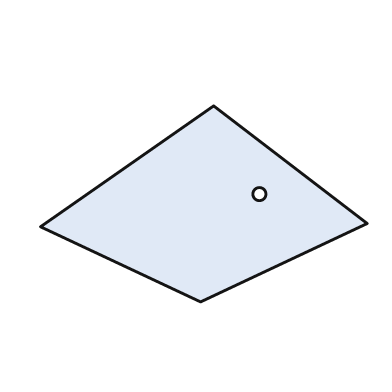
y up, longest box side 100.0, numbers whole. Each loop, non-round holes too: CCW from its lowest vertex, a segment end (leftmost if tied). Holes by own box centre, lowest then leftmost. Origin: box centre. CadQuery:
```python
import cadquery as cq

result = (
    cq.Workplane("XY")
    .moveTo(-1.0, -30.0)
    .lineTo(50.0, -6.0)
    .lineTo(3.0, 30.0)
    .lineTo(-50.0, -7.0)
    .close()
    .moveTo(17.0, 3.0)
    .circle(2.0)
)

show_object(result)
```